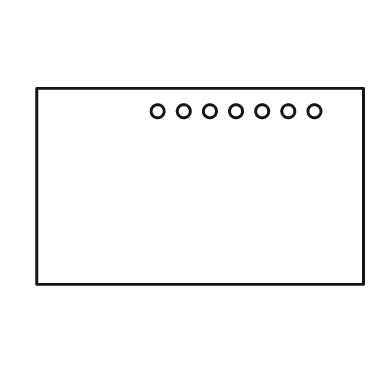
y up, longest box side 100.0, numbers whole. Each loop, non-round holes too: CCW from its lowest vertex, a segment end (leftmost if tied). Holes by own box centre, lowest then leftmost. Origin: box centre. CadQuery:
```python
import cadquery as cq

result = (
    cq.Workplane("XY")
    .moveTo(-50.0, -30.0)
    .lineTo(50.0, -30.0)
    .lineTo(50.0, 30.0)
    .lineTo(-50.0, 30.0)
    .close()
    .moveTo(-13.0, 23.0)
    .circle(2.0)
    .moveTo(-5.0, 23.0)
    .circle(2.0)
    .moveTo(3.0, 23.0)
    .circle(2.0)
    .moveTo(11.0, 23.0)
    .circle(2.0)
    .moveTo(19.0, 23.0)
    .circle(2.0)
    .moveTo(27.0, 23.0)
    .circle(2.0)
    .moveTo(35.0, 23.0)
    .circle(2.0)
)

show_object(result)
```